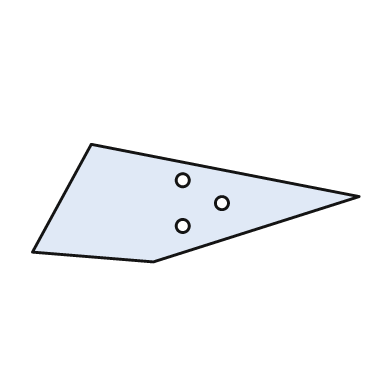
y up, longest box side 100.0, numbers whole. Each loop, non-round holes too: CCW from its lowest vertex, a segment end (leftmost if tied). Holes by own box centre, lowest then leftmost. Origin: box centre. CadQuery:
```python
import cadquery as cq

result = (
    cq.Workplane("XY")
    .moveTo(-13.0, -18.0)
    .lineTo(50.0, 2.0)
    .lineTo(-32.0, 18.0)
    .lineTo(-50.0, -15.0)
    .close()
    .moveTo(-4.0, -7.0)
    .circle(2.0)
    .moveTo(8.0, 0.0)
    .circle(2.0)
    .moveTo(-4.0, 7.0)
    .circle(2.0)
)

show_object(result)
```